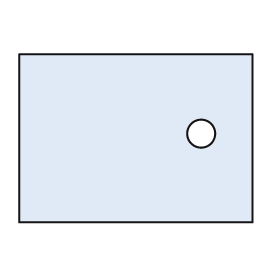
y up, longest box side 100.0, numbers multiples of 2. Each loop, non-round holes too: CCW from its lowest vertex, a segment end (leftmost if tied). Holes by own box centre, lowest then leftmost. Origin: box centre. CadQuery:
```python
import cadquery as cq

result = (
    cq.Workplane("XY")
    .moveTo(-50.0, -36.0)
    .lineTo(50.0, -36.0)
    .lineTo(50.0, 36.0)
    .lineTo(-50.0, 36.0)
    .close()
    .moveTo(28.0, 2.0)
    .circle(6.0)
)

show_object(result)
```